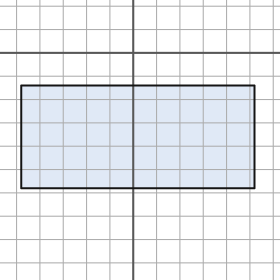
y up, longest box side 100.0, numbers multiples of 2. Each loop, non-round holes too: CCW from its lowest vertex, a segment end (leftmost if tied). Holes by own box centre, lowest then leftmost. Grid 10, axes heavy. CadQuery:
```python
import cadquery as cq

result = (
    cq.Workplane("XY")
    .moveTo(-48.0, -58.0)
    .lineTo(52.0, -58.0)
    .lineTo(52.0, -14.0)
    .lineTo(-48.0, -14.0)
    .close()
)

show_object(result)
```